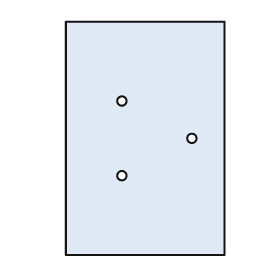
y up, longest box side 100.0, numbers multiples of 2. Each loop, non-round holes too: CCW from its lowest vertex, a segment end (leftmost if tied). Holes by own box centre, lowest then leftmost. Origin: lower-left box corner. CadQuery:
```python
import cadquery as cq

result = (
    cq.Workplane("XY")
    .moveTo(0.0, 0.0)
    .lineTo(68.0, 0.0)
    .lineTo(68.0, 100.0)
    .lineTo(0.0, 100.0)
    .close()
    .moveTo(24.0, 34.0)
    .circle(2.0)
    .moveTo(54.0, 50.0)
    .circle(2.0)
    .moveTo(24.0, 66.0)
    .circle(2.0)
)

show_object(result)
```